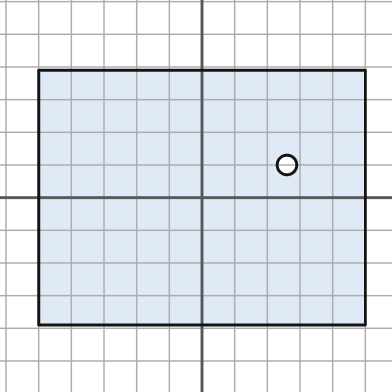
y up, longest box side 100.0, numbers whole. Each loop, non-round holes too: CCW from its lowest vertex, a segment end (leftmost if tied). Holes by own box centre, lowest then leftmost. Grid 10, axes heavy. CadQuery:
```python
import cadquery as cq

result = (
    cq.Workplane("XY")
    .moveTo(-50.0, -39.0)
    .lineTo(50.0, -39.0)
    .lineTo(50.0, 39.0)
    .lineTo(-50.0, 39.0)
    .close()
    .moveTo(26.0, 10.0)
    .circle(3.0)
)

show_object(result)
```